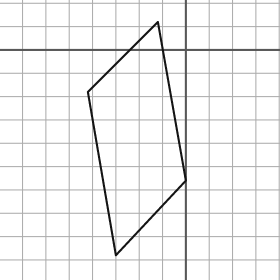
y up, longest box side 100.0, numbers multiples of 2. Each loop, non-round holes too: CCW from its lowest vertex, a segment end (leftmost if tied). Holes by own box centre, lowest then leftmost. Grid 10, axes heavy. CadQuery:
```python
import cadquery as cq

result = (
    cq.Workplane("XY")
    .moveTo(-30.0, -88.0)
    .lineTo(0.0, -56.0)
    .lineTo(-12.0, 12.0)
    .lineTo(-42.0, -18.0)
    .close()
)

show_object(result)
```